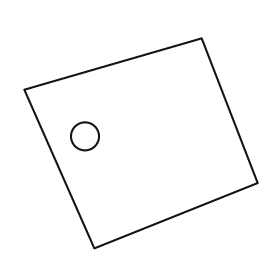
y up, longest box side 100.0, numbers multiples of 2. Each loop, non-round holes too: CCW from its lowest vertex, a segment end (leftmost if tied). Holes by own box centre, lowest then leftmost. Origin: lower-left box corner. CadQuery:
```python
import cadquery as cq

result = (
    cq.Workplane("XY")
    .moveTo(30.0, 0.0)
    .lineTo(100.0, 28.0)
    .lineTo(76.0, 90.0)
    .lineTo(0.0, 68.0)
    .close()
    .moveTo(26.0, 48.0)
    .circle(6.0)
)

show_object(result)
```